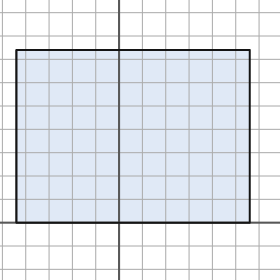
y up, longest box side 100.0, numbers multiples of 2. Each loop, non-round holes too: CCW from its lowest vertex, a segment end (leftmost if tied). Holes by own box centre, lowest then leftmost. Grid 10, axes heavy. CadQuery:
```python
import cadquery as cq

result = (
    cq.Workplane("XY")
    .moveTo(-44.0, 0.0)
    .lineTo(56.0, 0.0)
    .lineTo(56.0, 74.0)
    .lineTo(-44.0, 74.0)
    .close()
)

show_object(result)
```